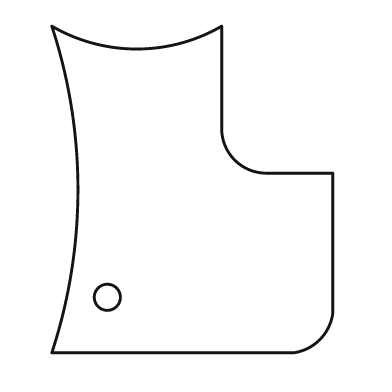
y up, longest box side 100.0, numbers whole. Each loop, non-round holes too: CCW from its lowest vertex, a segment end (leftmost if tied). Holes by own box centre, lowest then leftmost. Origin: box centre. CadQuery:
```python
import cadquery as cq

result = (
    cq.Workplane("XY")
    .moveTo(-43.0, -50.0)
    .lineTo(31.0, -50.0)
    .threePointArc((39.0, -46.0), (43.0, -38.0))
    .lineTo(43.0, 5.0)
    .lineTo(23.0, 5.0)
    .threePointArc((13.0, 9.0), (9.0, 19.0))
    .lineTo(9.0, 50.0)
    .threePointArc((-17.0, 43.0), (-43.0, 50.0))
    .threePointArc((-35.0, 0.0), (-43.0, -50.0))
    .close()
    .moveTo(-26.0, -33.0)
    .circle(4.0)
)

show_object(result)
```